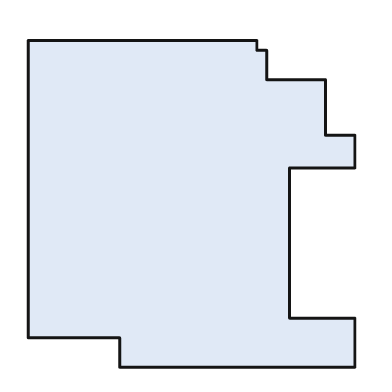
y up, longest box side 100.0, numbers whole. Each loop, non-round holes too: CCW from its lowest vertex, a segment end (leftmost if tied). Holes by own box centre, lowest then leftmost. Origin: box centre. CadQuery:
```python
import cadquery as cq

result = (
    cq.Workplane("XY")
    .moveTo(-22.0, -50.0)
    .lineTo(50.0, -50.0)
    .lineTo(50.0, -35.0)
    .lineTo(30.0, -35.0)
    .lineTo(30.0, 11.0)
    .lineTo(50.0, 11.0)
    .lineTo(50.0, 21.0)
    .lineTo(41.0, 21.0)
    .lineTo(41.0, 38.0)
    .lineTo(23.0, 38.0)
    .lineTo(23.0, 47.0)
    .lineTo(20.0, 47.0)
    .lineTo(20.0, 50.0)
    .lineTo(-50.0, 50.0)
    .lineTo(-50.0, -41.0)
    .lineTo(-22.0, -41.0)
    .close()
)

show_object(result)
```